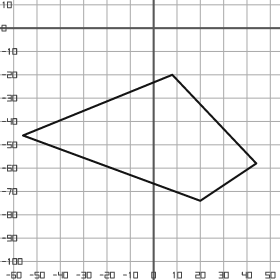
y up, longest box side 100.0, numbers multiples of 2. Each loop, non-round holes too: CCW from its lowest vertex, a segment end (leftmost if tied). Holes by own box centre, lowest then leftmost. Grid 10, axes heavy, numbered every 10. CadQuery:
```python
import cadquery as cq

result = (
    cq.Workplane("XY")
    .moveTo(20.0, -74.0)
    .lineTo(44.0, -58.0)
    .lineTo(8.0, -20.0)
    .lineTo(-56.0, -46.0)
    .close()
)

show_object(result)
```